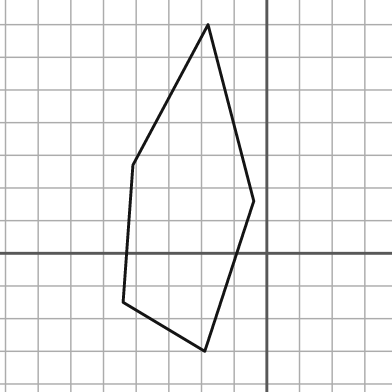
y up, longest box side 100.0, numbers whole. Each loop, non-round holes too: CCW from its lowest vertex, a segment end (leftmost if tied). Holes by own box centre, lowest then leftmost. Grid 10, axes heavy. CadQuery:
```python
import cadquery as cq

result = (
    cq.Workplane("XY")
    .moveTo(-19.0, -30.0)
    .lineTo(-4.0, 16.0)
    .lineTo(-18.0, 70.0)
    .lineTo(-41.0, 27.0)
    .lineTo(-44.0, -15.0)
    .close()
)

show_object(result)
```